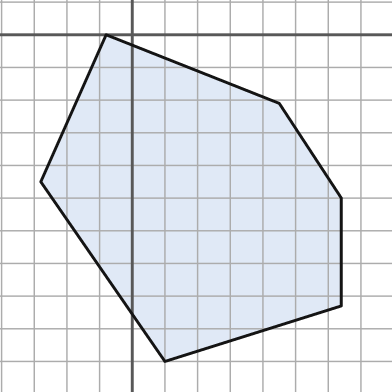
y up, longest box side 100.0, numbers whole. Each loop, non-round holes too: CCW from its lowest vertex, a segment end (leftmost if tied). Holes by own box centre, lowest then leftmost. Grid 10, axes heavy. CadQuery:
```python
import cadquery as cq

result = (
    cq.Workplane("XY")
    .moveTo(10.0, -100.0)
    .lineTo(64.0, -83.0)
    .lineTo(64.0, -50.0)
    .lineTo(45.0, -21.0)
    .lineTo(-8.0, 0.0)
    .lineTo(-28.0, -45.0)
    .close()
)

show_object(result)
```